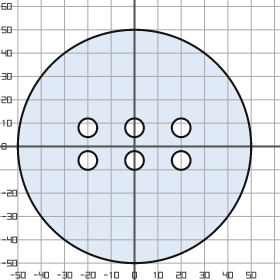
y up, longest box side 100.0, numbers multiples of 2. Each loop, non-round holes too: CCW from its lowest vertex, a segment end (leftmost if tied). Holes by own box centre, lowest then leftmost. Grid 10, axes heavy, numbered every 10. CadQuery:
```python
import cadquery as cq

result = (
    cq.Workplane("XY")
    .moveTo(0.0, 0.0)
    .circle(50.0)
    .moveTo(-20.0, -6.0)
    .circle(4.0)
    .moveTo(0.0, -6.0)
    .circle(4.0)
    .moveTo(20.0, -6.0)
    .circle(4.0)
    .moveTo(-20.0, 8.0)
    .circle(4.0)
    .moveTo(0.0, 8.0)
    .circle(4.0)
    .moveTo(20.0, 8.0)
    .circle(4.0)
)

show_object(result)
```